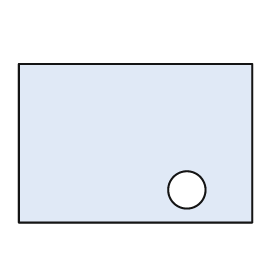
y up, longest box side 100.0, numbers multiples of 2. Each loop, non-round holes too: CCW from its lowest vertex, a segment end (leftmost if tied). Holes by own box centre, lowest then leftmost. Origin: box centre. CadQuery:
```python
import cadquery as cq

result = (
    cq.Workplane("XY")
    .moveTo(-50.0, -34.0)
    .lineTo(50.0, -34.0)
    .lineTo(50.0, 34.0)
    .lineTo(-50.0, 34.0)
    .close()
    .moveTo(22.0, -20.0)
    .circle(8.0)
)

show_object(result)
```